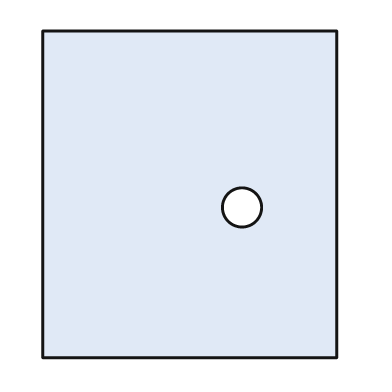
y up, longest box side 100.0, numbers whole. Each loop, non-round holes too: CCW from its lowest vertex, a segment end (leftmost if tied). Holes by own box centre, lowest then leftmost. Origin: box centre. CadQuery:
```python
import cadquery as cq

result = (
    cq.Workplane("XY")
    .moveTo(-45.0, -50.0)
    .lineTo(45.0, -50.0)
    .lineTo(45.0, 50.0)
    .lineTo(-45.0, 50.0)
    .close()
    .moveTo(16.0, -4.0)
    .circle(6.0)
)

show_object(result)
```